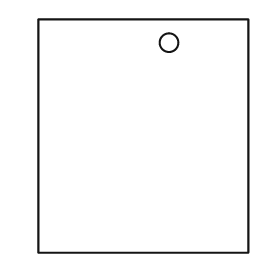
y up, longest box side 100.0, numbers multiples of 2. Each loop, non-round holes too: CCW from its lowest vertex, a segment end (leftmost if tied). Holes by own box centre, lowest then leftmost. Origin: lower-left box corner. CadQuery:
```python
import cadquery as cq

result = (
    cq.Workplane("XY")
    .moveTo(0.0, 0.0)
    .lineTo(90.0, 0.0)
    .lineTo(90.0, 100.0)
    .lineTo(0.0, 100.0)
    .close()
    .moveTo(56.0, 90.0)
    .circle(4.0)
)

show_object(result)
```